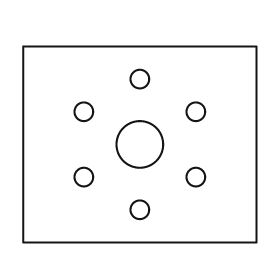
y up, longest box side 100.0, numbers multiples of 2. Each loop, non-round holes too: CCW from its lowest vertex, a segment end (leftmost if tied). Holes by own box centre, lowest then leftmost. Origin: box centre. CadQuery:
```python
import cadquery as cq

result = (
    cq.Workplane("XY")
    .moveTo(-50.0, -42.0)
    .lineTo(50.0, -42.0)
    .lineTo(50.0, 42.0)
    .lineTo(-50.0, 42.0)
    .close()
    .moveTo(0.0, -28.0)
    .circle(4.0)
    .moveTo(-24.0, -14.0)
    .circle(4.0)
    .moveTo(24.0, -14.0)
    .circle(4.0)
    .moveTo(0.0, 0.0)
    .circle(10.0)
    .moveTo(-24.0, 14.0)
    .circle(4.0)
    .moveTo(24.0, 14.0)
    .circle(4.0)
    .moveTo(0.0, 28.0)
    .circle(4.0)
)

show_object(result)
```